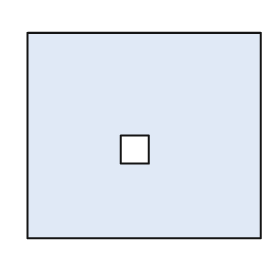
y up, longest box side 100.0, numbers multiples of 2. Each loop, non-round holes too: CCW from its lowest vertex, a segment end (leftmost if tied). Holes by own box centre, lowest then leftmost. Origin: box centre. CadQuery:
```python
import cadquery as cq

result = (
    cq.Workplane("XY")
    .moveTo(-50.0, -44.0)
    .lineTo(50.0, -44.0)
    .lineTo(50.0, 44.0)
    .lineTo(-50.0, 44.0)
    .close()
    .moveTo(-10.0, -12.0)
    .lineTo(2.0, -12.0)
    .lineTo(2.0, 0.0)
    .lineTo(-10.0, 0.0)
    .close()
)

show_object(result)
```